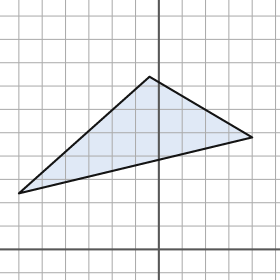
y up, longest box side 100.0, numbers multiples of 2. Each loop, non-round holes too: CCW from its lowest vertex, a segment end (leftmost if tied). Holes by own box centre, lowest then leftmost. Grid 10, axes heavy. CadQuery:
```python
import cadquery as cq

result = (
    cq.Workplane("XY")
    .moveTo(-60.0, 24.0)
    .lineTo(40.0, 48.0)
    .lineTo(-4.0, 74.0)
    .close()
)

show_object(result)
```